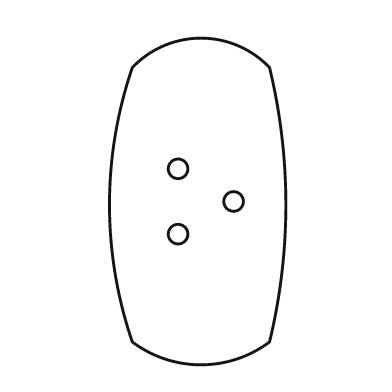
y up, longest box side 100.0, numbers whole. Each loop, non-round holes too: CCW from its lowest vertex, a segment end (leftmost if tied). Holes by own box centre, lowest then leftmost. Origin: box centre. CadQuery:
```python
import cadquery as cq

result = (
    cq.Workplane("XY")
    .moveTo(-20.0, -43.0)
    .threePointArc((1.0, -50.0), (22.0, -43.0))
    .threePointArc((27.0, -1.0), (22.0, 41.0))
    .threePointArc((1.0, 50.0), (-20.0, 41.0))
    .threePointArc((-27.0, -1.0), (-20.0, -43.0))
    .close()
    .moveTo(-6.0, -10.0)
    .circle(3.0)
    .moveTo(11.0, 0.0)
    .circle(3.0)
    .moveTo(-6.0, 10.0)
    .circle(3.0)
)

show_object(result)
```